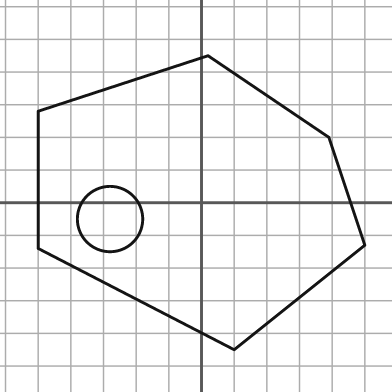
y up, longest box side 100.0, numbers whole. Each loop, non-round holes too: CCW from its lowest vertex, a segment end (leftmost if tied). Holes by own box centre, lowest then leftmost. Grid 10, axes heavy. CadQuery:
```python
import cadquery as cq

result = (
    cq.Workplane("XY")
    .moveTo(10.0, -45.0)
    .lineTo(50.0, -13.0)
    .lineTo(39.0, 20.0)
    .lineTo(2.0, 45.0)
    .lineTo(-50.0, 28.0)
    .lineTo(-50.0, -14.0)
    .close()
    .moveTo(-28.0, -5.0)
    .circle(10.0)
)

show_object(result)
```